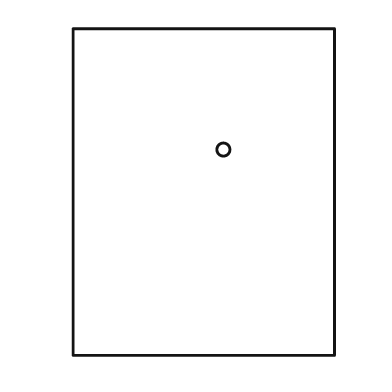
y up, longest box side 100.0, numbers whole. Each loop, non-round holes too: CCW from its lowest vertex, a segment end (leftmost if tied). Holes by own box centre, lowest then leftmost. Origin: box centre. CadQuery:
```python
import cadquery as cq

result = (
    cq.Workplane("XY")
    .moveTo(-40.0, -50.0)
    .lineTo(40.0, -50.0)
    .lineTo(40.0, 50.0)
    .lineTo(-40.0, 50.0)
    .close()
    .moveTo(6.0, 13.0)
    .circle(2.0)
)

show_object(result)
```